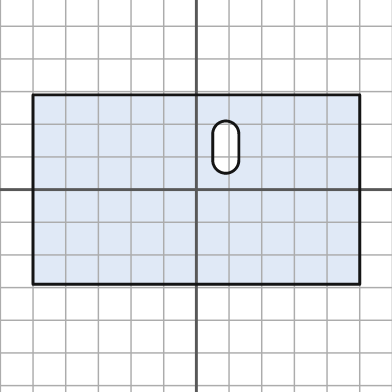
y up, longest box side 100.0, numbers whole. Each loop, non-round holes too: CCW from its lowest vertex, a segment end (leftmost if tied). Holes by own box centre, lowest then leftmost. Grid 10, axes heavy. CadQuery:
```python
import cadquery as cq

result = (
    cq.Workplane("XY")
    .moveTo(-50.0, -29.0)
    .lineTo(50.0, -29.0)
    .lineTo(50.0, 29.0)
    .lineTo(-50.0, 29.0)
    .close()
    .moveTo(5.0, 9.0)
    .threePointArc((9.0, 5.0), (13.0, 9.0))
    .lineTo(13.0, 17.0)
    .threePointArc((9.0, 21.0), (5.0, 17.0))
    .close()
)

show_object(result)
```